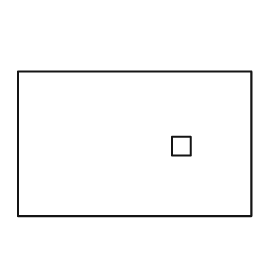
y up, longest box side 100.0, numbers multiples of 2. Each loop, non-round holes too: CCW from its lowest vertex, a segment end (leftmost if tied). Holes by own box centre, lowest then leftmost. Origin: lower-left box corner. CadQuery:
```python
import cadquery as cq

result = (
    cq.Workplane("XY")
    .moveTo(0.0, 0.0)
    .lineTo(100.0, 0.0)
    .lineTo(100.0, 62.0)
    .lineTo(0.0, 62.0)
    .close()
    .moveTo(66.0, 26.0)
    .lineTo(74.0, 26.0)
    .lineTo(74.0, 34.0)
    .lineTo(66.0, 34.0)
    .close()
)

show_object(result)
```